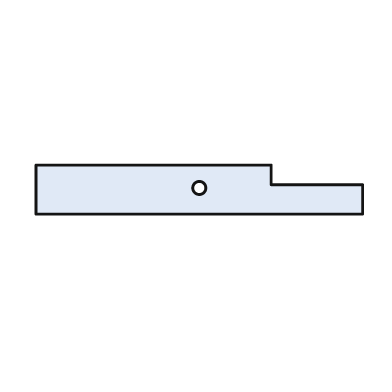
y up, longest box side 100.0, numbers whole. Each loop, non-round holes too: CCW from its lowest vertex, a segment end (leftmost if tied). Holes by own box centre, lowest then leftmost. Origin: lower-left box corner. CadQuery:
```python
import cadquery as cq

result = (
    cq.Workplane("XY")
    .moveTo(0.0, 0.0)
    .lineTo(100.0, 0.0)
    .lineTo(100.0, 9.0)
    .lineTo(72.0, 9.0)
    .lineTo(72.0, 15.0)
    .lineTo(0.0, 15.0)
    .close()
    .moveTo(50.0, 8.0)
    .circle(2.0)
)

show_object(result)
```